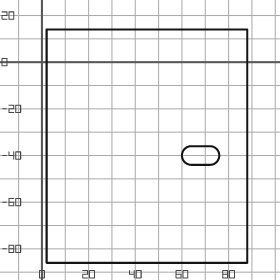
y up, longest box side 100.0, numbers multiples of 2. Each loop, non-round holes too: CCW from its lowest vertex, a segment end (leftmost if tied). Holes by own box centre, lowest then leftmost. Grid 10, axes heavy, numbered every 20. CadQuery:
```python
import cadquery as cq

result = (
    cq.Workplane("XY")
    .moveTo(2.0, -86.0)
    .lineTo(88.0, -86.0)
    .lineTo(88.0, 14.0)
    .lineTo(2.0, 14.0)
    .close()
    .moveTo(64.0, -44.0)
    .lineTo(72.0, -44.0)
    .threePointArc((76.0, -40.0), (72.0, -36.0))
    .lineTo(64.0, -36.0)
    .threePointArc((60.0, -40.0), (64.0, -44.0))
    .close()
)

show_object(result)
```